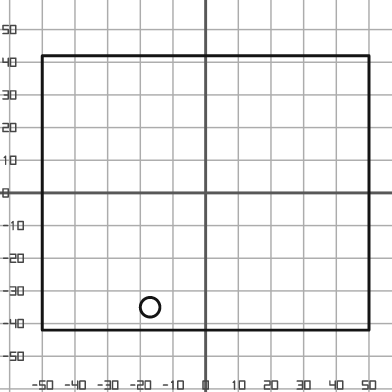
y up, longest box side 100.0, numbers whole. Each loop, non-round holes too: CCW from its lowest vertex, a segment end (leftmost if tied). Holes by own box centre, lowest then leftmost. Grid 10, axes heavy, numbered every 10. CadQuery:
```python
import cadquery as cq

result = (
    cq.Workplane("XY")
    .moveTo(-50.0, -42.0)
    .lineTo(50.0, -42.0)
    .lineTo(50.0, 42.0)
    .lineTo(-50.0, 42.0)
    .close()
    .moveTo(-17.0, -35.0)
    .circle(3.0)
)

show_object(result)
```